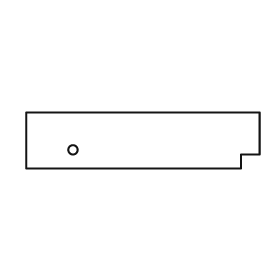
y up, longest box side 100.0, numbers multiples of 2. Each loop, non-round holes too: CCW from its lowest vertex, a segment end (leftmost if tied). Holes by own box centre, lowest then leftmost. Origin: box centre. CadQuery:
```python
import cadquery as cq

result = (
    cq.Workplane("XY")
    .moveTo(-50.0, -12.0)
    .lineTo(42.0, -12.0)
    .lineTo(42.0, -6.0)
    .lineTo(50.0, -6.0)
    .lineTo(50.0, 12.0)
    .lineTo(-50.0, 12.0)
    .close()
    .moveTo(-30.0, -4.0)
    .circle(2.0)
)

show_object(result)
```